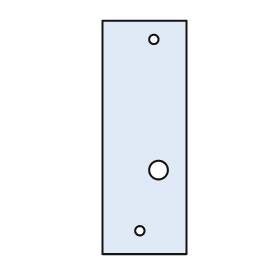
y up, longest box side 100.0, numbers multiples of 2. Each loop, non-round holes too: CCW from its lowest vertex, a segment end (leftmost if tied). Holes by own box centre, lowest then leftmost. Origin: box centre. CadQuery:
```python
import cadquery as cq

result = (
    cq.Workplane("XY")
    .moveTo(-18.0, -50.0)
    .lineTo(18.0, -50.0)
    .lineTo(18.0, 50.0)
    .lineTo(-18.0, 50.0)
    .close()
    .moveTo(-2.0, -40.0)
    .circle(2.0)
    .moveTo(6.0, -14.0)
    .circle(4.0)
    .moveTo(4.0, 42.0)
    .circle(2.0)
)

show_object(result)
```